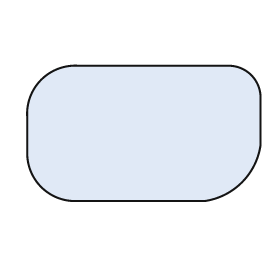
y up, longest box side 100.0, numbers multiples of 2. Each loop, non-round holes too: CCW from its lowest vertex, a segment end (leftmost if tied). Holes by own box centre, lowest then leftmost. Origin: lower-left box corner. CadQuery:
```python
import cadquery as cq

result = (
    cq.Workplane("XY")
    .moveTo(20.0, 0.0)
    .lineTo(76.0, 0.0)
    .threePointArc((92.0, 8.0), (100.0, 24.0))
    .lineTo(100.0, 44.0)
    .threePointArc((96.0, 54.0), (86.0, 58.0))
    .lineTo(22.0, 58.0)
    .threePointArc((6.0, 52.0), (0.0, 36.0))
    .lineTo(0.0, 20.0)
    .threePointArc((6.0, 6.0), (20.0, 0.0))
    .close()
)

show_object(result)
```